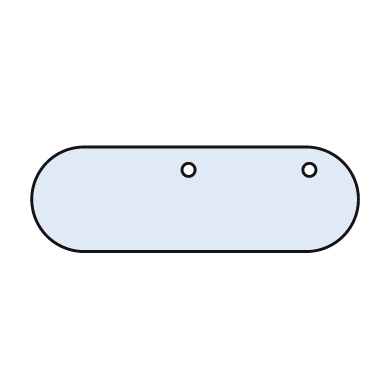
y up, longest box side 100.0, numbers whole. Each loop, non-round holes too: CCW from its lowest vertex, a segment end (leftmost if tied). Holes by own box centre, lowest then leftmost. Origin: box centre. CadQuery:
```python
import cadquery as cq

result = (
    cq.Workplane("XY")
    .moveTo(-34.0, -16.0)
    .lineTo(34.0, -16.0)
    .threePointArc((50.0, 0.0), (34.0, 16.0))
    .lineTo(-34.0, 16.0)
    .threePointArc((-50.0, 0.0), (-34.0, -16.0))
    .close()
    .moveTo(-2.0, 9.0)
    .circle(2.0)
    .moveTo(35.0, 9.0)
    .circle(2.0)
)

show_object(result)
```